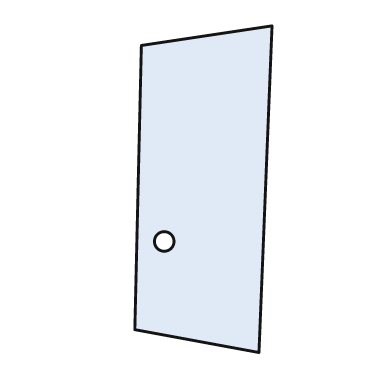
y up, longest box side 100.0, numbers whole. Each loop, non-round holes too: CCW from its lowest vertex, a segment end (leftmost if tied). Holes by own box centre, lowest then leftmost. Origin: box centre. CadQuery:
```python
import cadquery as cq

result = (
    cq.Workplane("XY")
    .moveTo(17.0, -50.0)
    .lineTo(21.0, 50.0)
    .lineTo(-19.0, 44.0)
    .lineTo(-21.0, -43.0)
    .close()
    .moveTo(-12.0, -16.0)
    .circle(3.0)
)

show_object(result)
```